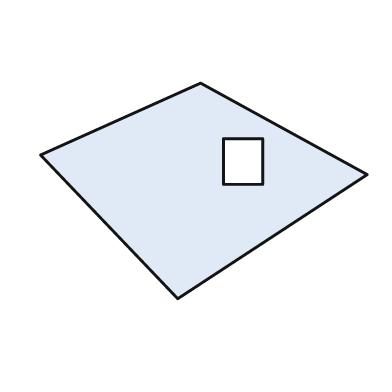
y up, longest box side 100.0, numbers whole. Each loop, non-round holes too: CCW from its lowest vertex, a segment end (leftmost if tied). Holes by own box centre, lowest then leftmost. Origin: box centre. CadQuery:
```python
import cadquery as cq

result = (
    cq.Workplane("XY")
    .moveTo(-8.0, -33.0)
    .lineTo(50.0, 5.0)
    .lineTo(-1.0, 33.0)
    .lineTo(-50.0, 11.0)
    .close()
    .moveTo(6.0, 2.0)
    .lineTo(18.0, 2.0)
    .lineTo(18.0, 16.0)
    .lineTo(6.0, 16.0)
    .close()
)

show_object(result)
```